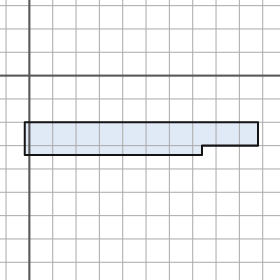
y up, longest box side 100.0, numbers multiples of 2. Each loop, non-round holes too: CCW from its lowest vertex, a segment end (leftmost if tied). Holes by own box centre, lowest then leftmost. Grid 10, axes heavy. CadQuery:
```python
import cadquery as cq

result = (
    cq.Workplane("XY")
    .moveTo(-2.0, -34.0)
    .lineTo(74.0, -34.0)
    .lineTo(74.0, -30.0)
    .lineTo(98.0, -30.0)
    .lineTo(98.0, -20.0)
    .lineTo(-2.0, -20.0)
    .close()
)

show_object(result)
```